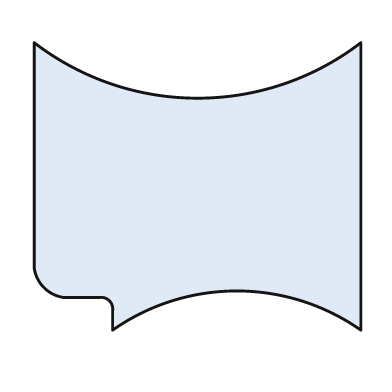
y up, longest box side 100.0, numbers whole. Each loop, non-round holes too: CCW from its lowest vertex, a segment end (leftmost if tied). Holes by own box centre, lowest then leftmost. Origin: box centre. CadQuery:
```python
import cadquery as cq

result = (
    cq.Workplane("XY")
    .moveTo(-26.0, -44.0)
    .threePointArc((12.0, -32.0), (50.0, -44.0))
    .lineTo(50.0, 44.0)
    .threePointArc((0.0, 27.0), (-50.0, 44.0))
    .lineTo(-50.0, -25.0)
    .threePointArc((-47.0, -31.0), (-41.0, -34.0))
    .lineTo(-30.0, -34.0)
    .threePointArc((-27.0, -35.0), (-26.0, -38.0))
    .close()
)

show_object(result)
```